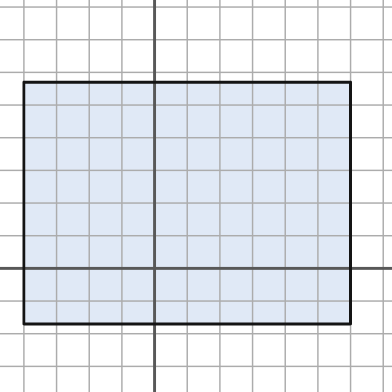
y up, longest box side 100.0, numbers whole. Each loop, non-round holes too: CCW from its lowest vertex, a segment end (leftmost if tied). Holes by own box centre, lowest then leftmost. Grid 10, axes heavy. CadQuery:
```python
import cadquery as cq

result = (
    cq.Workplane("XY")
    .moveTo(-40.0, -17.0)
    .lineTo(60.0, -17.0)
    .lineTo(60.0, 57.0)
    .lineTo(-40.0, 57.0)
    .close()
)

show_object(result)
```